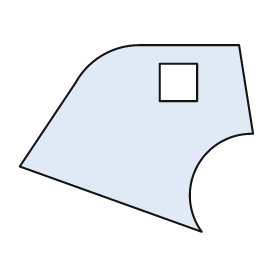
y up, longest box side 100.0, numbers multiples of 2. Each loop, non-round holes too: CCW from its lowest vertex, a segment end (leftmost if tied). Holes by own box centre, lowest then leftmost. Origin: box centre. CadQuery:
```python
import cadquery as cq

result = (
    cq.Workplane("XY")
    .moveTo(28.0, -40.0)
    .threePointArc((26.0, -12.0), (50.0, 2.0))
    .lineTo(44.0, 40.0)
    .lineTo(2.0, 40.0)
    .threePointArc((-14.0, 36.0), (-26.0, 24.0))
    .lineTo(-50.0, -12.0)
    .close()
    .moveTo(10.0, 16.0)
    .lineTo(26.0, 16.0)
    .lineTo(26.0, 32.0)
    .lineTo(10.0, 32.0)
    .close()
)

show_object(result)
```